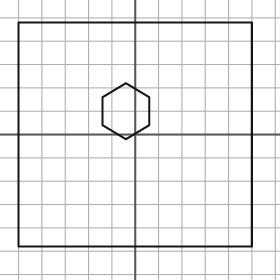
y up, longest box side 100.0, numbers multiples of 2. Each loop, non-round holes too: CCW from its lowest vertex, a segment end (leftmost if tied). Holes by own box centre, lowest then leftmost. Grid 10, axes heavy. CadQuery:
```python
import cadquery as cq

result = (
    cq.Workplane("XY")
    .moveTo(-50.0, -48.0)
    .lineTo(50.0, -48.0)
    .lineTo(50.0, 48.0)
    .lineTo(-50.0, 48.0)
    .close()
    .moveTo(-4.0, -2.0)
    .lineTo(6.0, 4.0)
    .lineTo(6.0, 16.0)
    .lineTo(-4.0, 22.0)
    .lineTo(-14.0, 16.0)
    .lineTo(-14.0, 4.0)
    .close()
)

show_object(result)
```